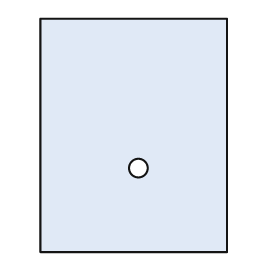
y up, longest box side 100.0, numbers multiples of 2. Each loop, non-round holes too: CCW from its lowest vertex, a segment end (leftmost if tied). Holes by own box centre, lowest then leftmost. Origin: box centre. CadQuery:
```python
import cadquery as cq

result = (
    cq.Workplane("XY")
    .moveTo(-40.0, -50.0)
    .lineTo(40.0, -50.0)
    .lineTo(40.0, 50.0)
    .lineTo(-40.0, 50.0)
    .close()
    .moveTo(2.0, -14.0)
    .circle(4.0)
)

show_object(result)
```